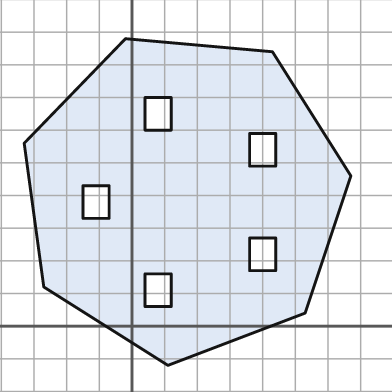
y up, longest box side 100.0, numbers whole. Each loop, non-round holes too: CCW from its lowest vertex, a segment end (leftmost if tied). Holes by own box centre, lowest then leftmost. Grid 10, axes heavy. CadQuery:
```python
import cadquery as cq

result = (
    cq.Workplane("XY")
    .moveTo(11.0, -12.0)
    .lineTo(53.0, 4.0)
    .lineTo(67.0, 46.0)
    .lineTo(43.0, 84.0)
    .lineTo(-2.0, 88.0)
    .lineTo(-33.0, 56.0)
    .lineTo(-27.0, 12.0)
    .close()
    .moveTo(4.0, 6.0)
    .lineTo(12.0, 6.0)
    .lineTo(12.0, 16.0)
    .lineTo(4.0, 16.0)
    .close()
    .moveTo(36.0, 17.0)
    .lineTo(44.0, 17.0)
    .lineTo(44.0, 27.0)
    .lineTo(36.0, 27.0)
    .close()
    .moveTo(-15.0, 33.0)
    .lineTo(-7.0, 33.0)
    .lineTo(-7.0, 43.0)
    .lineTo(-15.0, 43.0)
    .close()
    .moveTo(36.0, 49.0)
    .lineTo(44.0, 49.0)
    .lineTo(44.0, 59.0)
    .lineTo(36.0, 59.0)
    .close()
    .moveTo(4.0, 60.0)
    .lineTo(12.0, 60.0)
    .lineTo(12.0, 70.0)
    .lineTo(4.0, 70.0)
    .close()
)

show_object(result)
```